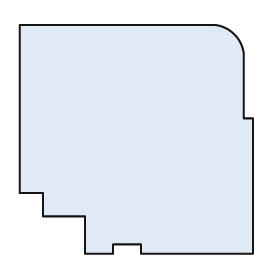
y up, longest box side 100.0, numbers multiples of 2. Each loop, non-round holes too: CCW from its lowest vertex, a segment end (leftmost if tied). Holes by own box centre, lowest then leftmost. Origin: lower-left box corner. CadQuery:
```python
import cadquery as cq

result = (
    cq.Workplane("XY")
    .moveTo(28.0, 0.0)
    .lineTo(40.0, 0.0)
    .lineTo(40.0, 4.0)
    .lineTo(52.0, 4.0)
    .lineTo(52.0, 0.0)
    .lineTo(100.0, 0.0)
    .lineTo(100.0, 58.0)
    .lineTo(96.0, 58.0)
    .lineTo(96.0, 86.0)
    .threePointArc((92.0, 94.0), (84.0, 98.0))
    .lineTo(0.0, 98.0)
    .lineTo(0.0, 26.0)
    .lineTo(10.0, 26.0)
    .lineTo(10.0, 16.0)
    .lineTo(28.0, 16.0)
    .close()
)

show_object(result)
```